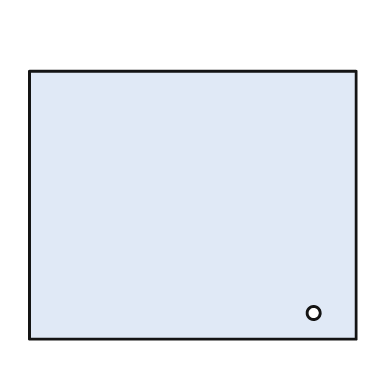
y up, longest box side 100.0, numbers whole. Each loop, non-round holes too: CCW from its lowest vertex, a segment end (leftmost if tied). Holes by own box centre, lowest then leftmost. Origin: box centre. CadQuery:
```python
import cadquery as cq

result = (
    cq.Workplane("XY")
    .moveTo(-50.0, -41.0)
    .lineTo(50.0, -41.0)
    .lineTo(50.0, 41.0)
    .lineTo(-50.0, 41.0)
    .close()
    .moveTo(37.0, -33.0)
    .circle(2.0)
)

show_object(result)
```